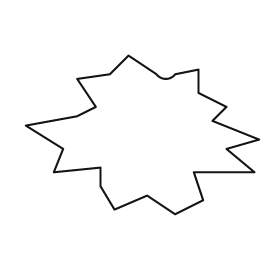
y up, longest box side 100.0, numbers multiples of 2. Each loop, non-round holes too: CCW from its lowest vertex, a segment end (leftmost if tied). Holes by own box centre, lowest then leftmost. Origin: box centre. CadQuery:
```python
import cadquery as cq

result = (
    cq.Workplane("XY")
    .moveTo(14.0, -34.0)
    .lineTo(26.0, -28.0)
    .lineTo(22.0, -16.0)
    .lineTo(48.0, -16.0)
    .lineTo(36.0, -6.0)
    .lineTo(50.0, -2.0)
    .lineTo(30.0, 6.0)
    .lineTo(36.0, 12.0)
    .lineTo(24.0, 18.0)
    .lineTo(24.0, 28.0)
    .lineTo(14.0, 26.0)
    .threePointArc((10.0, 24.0), (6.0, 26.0))
    .lineTo(-6.0, 34.0)
    .lineTo(-14.0, 26.0)
    .lineTo(-28.0, 24.0)
    .lineTo(-20.0, 12.0)
    .lineTo(-28.0, 8.0)
    .lineTo(-50.0, 4.0)
    .lineTo(-34.0, -6.0)
    .lineTo(-38.0, -16.0)
    .lineTo(-18.0, -14.0)
    .lineTo(-18.0, -22.0)
    .lineTo(-12.0, -32.0)
    .lineTo(2.0, -26.0)
    .close()
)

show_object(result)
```